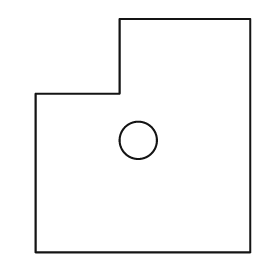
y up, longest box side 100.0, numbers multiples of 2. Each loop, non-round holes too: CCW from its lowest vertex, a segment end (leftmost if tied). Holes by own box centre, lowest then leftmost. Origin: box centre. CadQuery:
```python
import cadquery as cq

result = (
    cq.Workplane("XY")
    .moveTo(-46.0, -50.0)
    .lineTo(46.0, -50.0)
    .lineTo(46.0, 50.0)
    .lineTo(-10.0, 50.0)
    .lineTo(-10.0, 18.0)
    .lineTo(-46.0, 18.0)
    .close()
    .moveTo(-2.0, -2.0)
    .circle(8.0)
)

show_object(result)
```